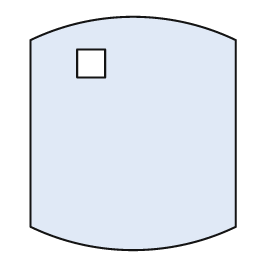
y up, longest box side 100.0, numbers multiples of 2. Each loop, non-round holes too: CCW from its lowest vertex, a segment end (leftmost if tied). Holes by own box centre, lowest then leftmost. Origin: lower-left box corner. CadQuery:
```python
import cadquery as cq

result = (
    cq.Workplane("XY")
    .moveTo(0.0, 10.0)
    .threePointArc((44.0, 0.0), (88.0, 10.0))
    .lineTo(88.0, 90.0)
    .threePointArc((44.0, 100.0), (0.0, 90.0))
    .close()
    .moveTo(20.0, 74.0)
    .lineTo(32.0, 74.0)
    .lineTo(32.0, 86.0)
    .lineTo(20.0, 86.0)
    .close()
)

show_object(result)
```